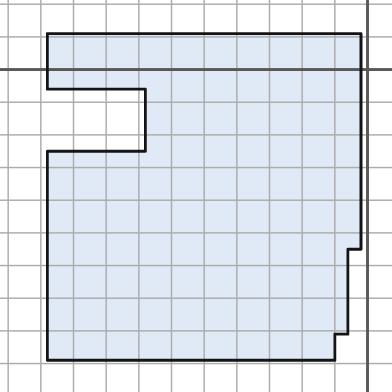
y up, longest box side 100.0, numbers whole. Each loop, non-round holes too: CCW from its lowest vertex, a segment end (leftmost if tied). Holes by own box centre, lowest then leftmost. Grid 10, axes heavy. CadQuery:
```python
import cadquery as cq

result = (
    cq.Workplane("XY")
    .moveTo(-98.0, -89.0)
    .lineTo(-10.0, -89.0)
    .lineTo(-10.0, -81.0)
    .lineTo(-6.0, -81.0)
    .lineTo(-6.0, -55.0)
    .lineTo(-2.0, -55.0)
    .lineTo(-2.0, 11.0)
    .lineTo(-98.0, 11.0)
    .lineTo(-98.0, -6.0)
    .lineTo(-68.0, -6.0)
    .lineTo(-68.0, -25.0)
    .lineTo(-98.0, -25.0)
    .close()
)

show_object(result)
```